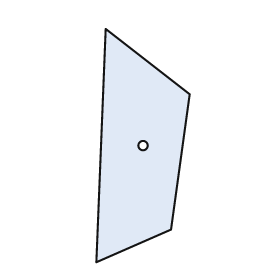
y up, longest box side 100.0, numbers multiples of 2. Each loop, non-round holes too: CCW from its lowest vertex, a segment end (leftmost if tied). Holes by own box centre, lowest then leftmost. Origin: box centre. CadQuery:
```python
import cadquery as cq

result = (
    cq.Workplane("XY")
    .moveTo(-20.0, -50.0)
    .lineTo(12.0, -36.0)
    .lineTo(20.0, 22.0)
    .lineTo(-16.0, 50.0)
    .close()
    .moveTo(0.0, 0.0)
    .circle(2.0)
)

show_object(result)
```